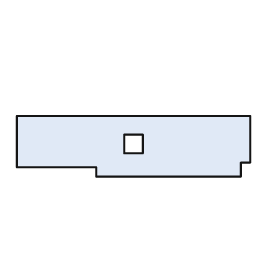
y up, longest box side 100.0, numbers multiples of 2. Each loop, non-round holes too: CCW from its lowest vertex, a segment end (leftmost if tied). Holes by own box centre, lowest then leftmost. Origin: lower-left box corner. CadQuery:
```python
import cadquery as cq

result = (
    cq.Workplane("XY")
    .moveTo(34.0, 0.0)
    .lineTo(96.0, 0.0)
    .lineTo(96.0, 6.0)
    .lineTo(100.0, 6.0)
    .lineTo(100.0, 26.0)
    .lineTo(0.0, 26.0)
    .lineTo(0.0, 4.0)
    .lineTo(34.0, 4.0)
    .close()
    .moveTo(46.0, 10.0)
    .lineTo(54.0, 10.0)
    .lineTo(54.0, 18.0)
    .lineTo(46.0, 18.0)
    .close()
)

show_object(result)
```